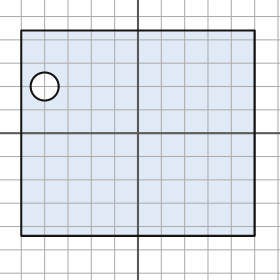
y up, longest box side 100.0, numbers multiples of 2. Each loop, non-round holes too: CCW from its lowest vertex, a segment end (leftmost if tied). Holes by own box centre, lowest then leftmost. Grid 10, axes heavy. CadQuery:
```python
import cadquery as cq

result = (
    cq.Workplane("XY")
    .moveTo(-50.0, -44.0)
    .lineTo(50.0, -44.0)
    .lineTo(50.0, 44.0)
    .lineTo(-50.0, 44.0)
    .close()
    .moveTo(-40.0, 20.0)
    .circle(6.0)
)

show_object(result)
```